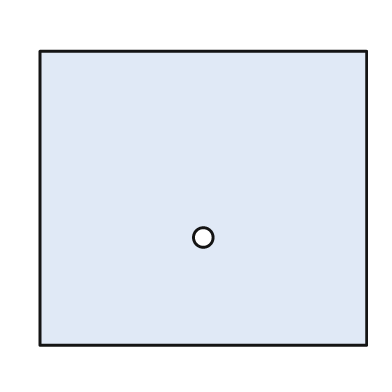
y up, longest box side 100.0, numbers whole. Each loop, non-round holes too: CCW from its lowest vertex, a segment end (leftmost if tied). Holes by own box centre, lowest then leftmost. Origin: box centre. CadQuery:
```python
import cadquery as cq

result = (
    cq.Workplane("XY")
    .moveTo(-50.0, -45.0)
    .lineTo(50.0, -45.0)
    .lineTo(50.0, 45.0)
    .lineTo(-50.0, 45.0)
    .close()
    .moveTo(0.0, -12.0)
    .circle(3.0)
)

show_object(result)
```